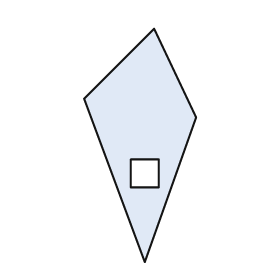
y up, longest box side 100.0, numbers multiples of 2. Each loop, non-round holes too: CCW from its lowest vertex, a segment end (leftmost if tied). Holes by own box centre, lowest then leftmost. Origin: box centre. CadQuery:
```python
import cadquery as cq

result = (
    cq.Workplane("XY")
    .moveTo(2.0, -50.0)
    .lineTo(24.0, 12.0)
    .lineTo(6.0, 50.0)
    .lineTo(-24.0, 20.0)
    .close()
    .moveTo(-4.0, -18.0)
    .lineTo(8.0, -18.0)
    .lineTo(8.0, -6.0)
    .lineTo(-4.0, -6.0)
    .close()
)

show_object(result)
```